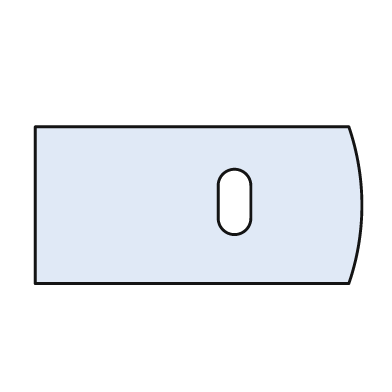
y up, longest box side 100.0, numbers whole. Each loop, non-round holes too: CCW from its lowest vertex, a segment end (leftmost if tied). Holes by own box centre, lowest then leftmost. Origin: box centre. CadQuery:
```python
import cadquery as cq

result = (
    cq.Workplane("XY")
    .moveTo(-50.0, -24.0)
    .lineTo(46.0, -24.0)
    .threePointArc((50.0, 0.0), (46.0, 24.0))
    .lineTo(-50.0, 24.0)
    .close()
    .moveTo(6.0, -4.0)
    .threePointArc((11.0, -9.0), (16.0, -4.0))
    .lineTo(16.0, 6.0)
    .threePointArc((11.0, 11.0), (6.0, 6.0))
    .close()
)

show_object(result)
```